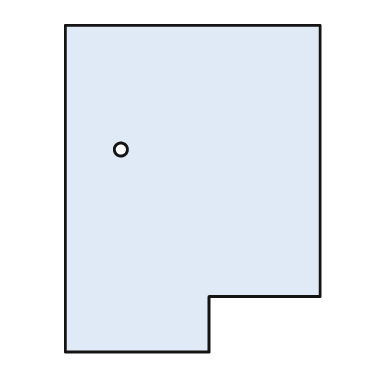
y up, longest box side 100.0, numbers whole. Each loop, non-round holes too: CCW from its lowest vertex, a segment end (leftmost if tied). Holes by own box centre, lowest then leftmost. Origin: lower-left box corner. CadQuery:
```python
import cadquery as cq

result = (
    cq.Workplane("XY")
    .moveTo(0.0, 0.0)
    .lineTo(44.0, 0.0)
    .lineTo(44.0, 17.0)
    .lineTo(78.0, 17.0)
    .lineTo(78.0, 100.0)
    .lineTo(0.0, 100.0)
    .close()
    .moveTo(17.0, 62.0)
    .circle(2.0)
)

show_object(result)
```